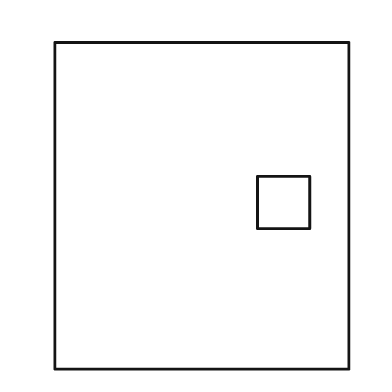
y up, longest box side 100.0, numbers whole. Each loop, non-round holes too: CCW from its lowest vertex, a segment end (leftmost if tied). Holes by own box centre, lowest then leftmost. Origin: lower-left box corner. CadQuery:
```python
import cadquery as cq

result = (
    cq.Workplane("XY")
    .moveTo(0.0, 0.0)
    .lineTo(90.0, 0.0)
    .lineTo(90.0, 100.0)
    .lineTo(0.0, 100.0)
    .close()
    .moveTo(62.0, 43.0)
    .lineTo(78.0, 43.0)
    .lineTo(78.0, 59.0)
    .lineTo(62.0, 59.0)
    .close()
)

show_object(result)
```